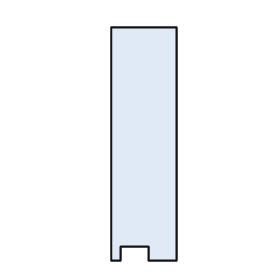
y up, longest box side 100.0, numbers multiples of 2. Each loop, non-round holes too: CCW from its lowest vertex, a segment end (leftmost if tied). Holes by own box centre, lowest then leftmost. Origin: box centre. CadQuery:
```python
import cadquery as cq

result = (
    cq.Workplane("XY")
    .moveTo(-14.0, -50.0)
    .lineTo(-10.0, -50.0)
    .lineTo(-10.0, -44.0)
    .lineTo(2.0, -44.0)
    .lineTo(2.0, -50.0)
    .lineTo(14.0, -50.0)
    .lineTo(14.0, 50.0)
    .lineTo(-14.0, 50.0)
    .close()
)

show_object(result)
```